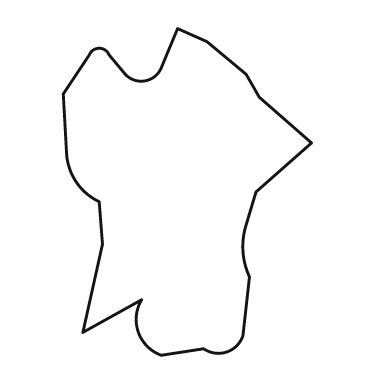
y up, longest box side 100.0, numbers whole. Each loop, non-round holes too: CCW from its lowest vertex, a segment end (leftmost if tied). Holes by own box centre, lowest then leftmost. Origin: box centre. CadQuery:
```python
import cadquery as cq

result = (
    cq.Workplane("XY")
    .moveTo(-8.0, -50.0)
    .lineTo(5.0, -48.0)
    .threePointArc((12.0, -49.0), (17.0, -44.0))
    .lineTo(19.0, -26.0)
    .threePointArc((17.0, -18.0), (18.0, -10.0))
    .lineTo(21.0, 0.0)
    .lineTo(38.0, 15.0)
    .lineTo(22.0, 29.0)
    .lineTo(18.0, 36.0)
    .lineTo(6.0, 46.0)
    .lineTo(-3.0, 50.0)
    .lineTo(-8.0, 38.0)
    .threePointArc((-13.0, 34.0), (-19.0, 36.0))
    .lineTo(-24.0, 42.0)
    .threePointArc((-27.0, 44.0), (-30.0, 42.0))
    .lineTo(-38.0, 30.0)
    .lineTo(-37.0, 12.0)
    .threePointArc((-34.0, 3.0), (-27.0, -3.0))
    .lineTo(-26.0, -16.0)
    .lineTo(-32.0, -43.0)
    .lineTo(-14.0, -33.0)
    .threePointArc((-15.0, -43.0), (-8.0, -50.0))
    .close()
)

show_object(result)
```